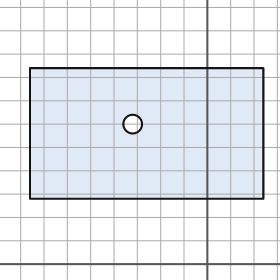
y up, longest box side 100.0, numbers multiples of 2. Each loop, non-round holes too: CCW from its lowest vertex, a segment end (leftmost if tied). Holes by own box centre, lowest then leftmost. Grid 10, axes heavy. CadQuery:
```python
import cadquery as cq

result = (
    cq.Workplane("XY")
    .moveTo(-76.0, 28.0)
    .lineTo(24.0, 28.0)
    .lineTo(24.0, 84.0)
    .lineTo(-76.0, 84.0)
    .close()
    .moveTo(-32.0, 60.0)
    .circle(4.0)
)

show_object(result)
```